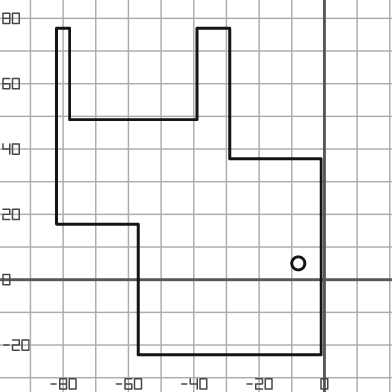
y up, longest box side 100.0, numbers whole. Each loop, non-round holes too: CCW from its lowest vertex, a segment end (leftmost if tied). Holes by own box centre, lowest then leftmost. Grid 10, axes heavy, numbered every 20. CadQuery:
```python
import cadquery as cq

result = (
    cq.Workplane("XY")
    .moveTo(-57.0, -23.0)
    .lineTo(-1.0, -23.0)
    .lineTo(-1.0, 37.0)
    .lineTo(-29.0, 37.0)
    .lineTo(-29.0, 77.0)
    .lineTo(-39.0, 77.0)
    .lineTo(-39.0, 49.0)
    .lineTo(-78.0, 49.0)
    .lineTo(-78.0, 77.0)
    .lineTo(-82.0, 77.0)
    .lineTo(-82.0, 17.0)
    .lineTo(-57.0, 17.0)
    .close()
    .moveTo(-8.0, 5.0)
    .circle(2.0)
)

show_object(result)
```